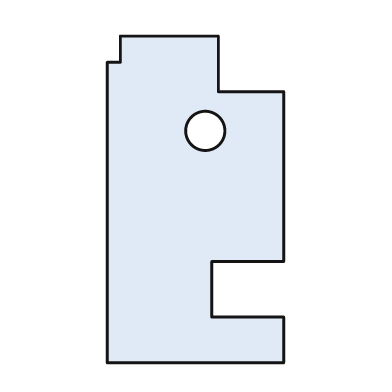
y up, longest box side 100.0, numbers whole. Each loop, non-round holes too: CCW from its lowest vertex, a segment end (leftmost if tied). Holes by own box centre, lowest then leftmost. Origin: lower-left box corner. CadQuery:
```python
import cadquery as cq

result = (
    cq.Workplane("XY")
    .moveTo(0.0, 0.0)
    .lineTo(54.0, 0.0)
    .lineTo(54.0, 14.0)
    .lineTo(32.0, 14.0)
    .lineTo(32.0, 31.0)
    .lineTo(54.0, 31.0)
    .lineTo(54.0, 83.0)
    .lineTo(34.0, 83.0)
    .lineTo(34.0, 100.0)
    .lineTo(4.0, 100.0)
    .lineTo(4.0, 92.0)
    .lineTo(0.0, 92.0)
    .close()
    .moveTo(30.0, 71.0)
    .circle(6.0)
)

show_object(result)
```